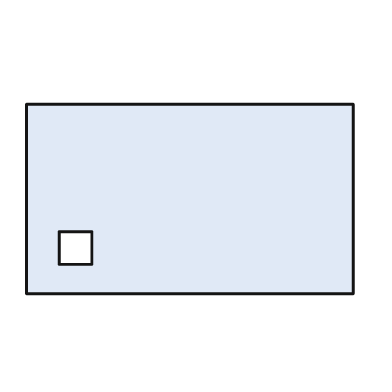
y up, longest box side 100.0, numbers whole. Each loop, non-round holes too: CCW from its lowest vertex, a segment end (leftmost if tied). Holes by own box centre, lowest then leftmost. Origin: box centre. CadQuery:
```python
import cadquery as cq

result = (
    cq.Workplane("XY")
    .moveTo(-50.0, -29.0)
    .lineTo(50.0, -29.0)
    .lineTo(50.0, 29.0)
    .lineTo(-50.0, 29.0)
    .close()
    .moveTo(-40.0, -20.0)
    .lineTo(-30.0, -20.0)
    .lineTo(-30.0, -10.0)
    .lineTo(-40.0, -10.0)
    .close()
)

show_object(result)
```